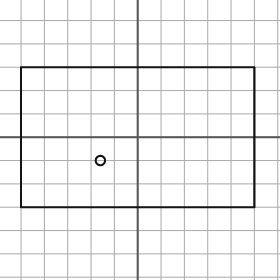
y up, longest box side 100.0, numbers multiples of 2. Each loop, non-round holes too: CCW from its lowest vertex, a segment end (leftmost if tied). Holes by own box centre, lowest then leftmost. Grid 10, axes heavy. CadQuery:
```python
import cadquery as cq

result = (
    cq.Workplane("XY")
    .moveTo(-50.0, -30.0)
    .lineTo(50.0, -30.0)
    .lineTo(50.0, 30.0)
    .lineTo(-50.0, 30.0)
    .close()
    .moveTo(-16.0, -10.0)
    .circle(2.0)
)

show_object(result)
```